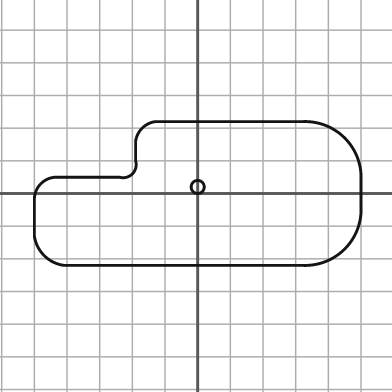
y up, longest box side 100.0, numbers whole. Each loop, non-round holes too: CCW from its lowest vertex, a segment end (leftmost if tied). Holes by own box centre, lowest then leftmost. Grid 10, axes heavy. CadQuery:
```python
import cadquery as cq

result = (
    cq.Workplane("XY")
    .moveTo(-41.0, -22.0)
    .lineTo(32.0, -22.0)
    .threePointArc((45.0, -17.0), (50.0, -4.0))
    .lineTo(50.0, 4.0)
    .threePointArc((45.0, 17.0), (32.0, 22.0))
    .lineTo(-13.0, 22.0)
    .threePointArc((-17.0, 20.0), (-19.0, 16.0))
    .lineTo(-19.0, 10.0)
    .threePointArc((-20.0, 6.0), (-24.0, 5.0))
    .lineTo(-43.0, 5.0)
    .threePointArc((-48.0, 3.0), (-50.0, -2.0))
    .lineTo(-50.0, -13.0)
    .threePointArc((-47.0, -19.0), (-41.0, -22.0))
    .close()
    .moveTo(0.0, 2.0)
    .circle(2.0)
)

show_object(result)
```